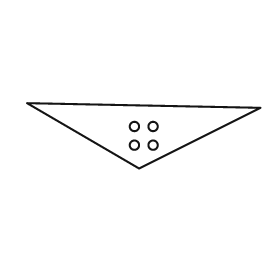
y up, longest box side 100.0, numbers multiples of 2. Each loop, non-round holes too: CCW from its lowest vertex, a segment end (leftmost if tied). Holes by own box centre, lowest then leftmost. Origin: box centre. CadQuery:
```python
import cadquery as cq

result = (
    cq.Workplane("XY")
    .moveTo(-2.0, -14.0)
    .lineTo(50.0, 12.0)
    .lineTo(-50.0, 14.0)
    .close()
    .moveTo(-4.0, -4.0)
    .circle(2.0)
    .moveTo(4.0, -4.0)
    .circle(2.0)
    .moveTo(-4.0, 4.0)
    .circle(2.0)
    .moveTo(4.0, 4.0)
    .circle(2.0)
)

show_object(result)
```